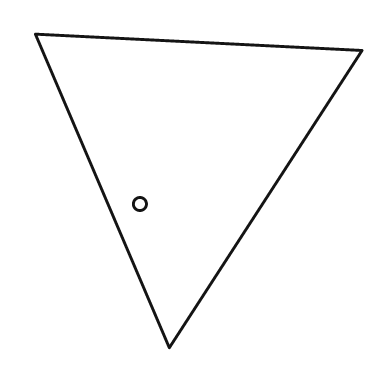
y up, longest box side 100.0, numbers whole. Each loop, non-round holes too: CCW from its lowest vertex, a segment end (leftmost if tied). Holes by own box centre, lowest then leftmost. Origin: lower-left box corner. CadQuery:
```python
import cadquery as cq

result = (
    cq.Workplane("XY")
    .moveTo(41.0, 0.0)
    .lineTo(100.0, 91.0)
    .lineTo(0.0, 96.0)
    .close()
    .moveTo(32.0, 44.0)
    .circle(2.0)
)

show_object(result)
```